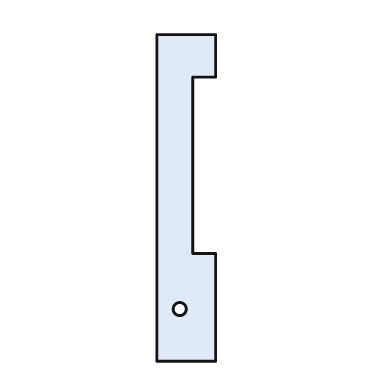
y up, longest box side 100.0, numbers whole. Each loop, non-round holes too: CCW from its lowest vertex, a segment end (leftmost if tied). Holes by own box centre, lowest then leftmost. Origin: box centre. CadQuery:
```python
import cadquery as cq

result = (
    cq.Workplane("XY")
    .moveTo(-9.0, -50.0)
    .lineTo(9.0, -50.0)
    .lineTo(9.0, -17.0)
    .lineTo(2.0, -17.0)
    .lineTo(2.0, 37.0)
    .lineTo(9.0, 37.0)
    .lineTo(9.0, 50.0)
    .lineTo(-9.0, 50.0)
    .close()
    .moveTo(-2.0, -34.0)
    .circle(2.0)
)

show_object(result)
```